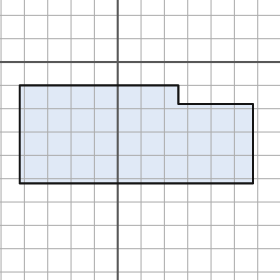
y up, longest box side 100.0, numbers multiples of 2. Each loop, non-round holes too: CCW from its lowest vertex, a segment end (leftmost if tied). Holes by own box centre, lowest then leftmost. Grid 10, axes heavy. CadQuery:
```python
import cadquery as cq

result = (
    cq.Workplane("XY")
    .moveTo(-42.0, -52.0)
    .lineTo(58.0, -52.0)
    .lineTo(58.0, -18.0)
    .lineTo(26.0, -18.0)
    .lineTo(26.0, -10.0)
    .lineTo(-42.0, -10.0)
    .close()
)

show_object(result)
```